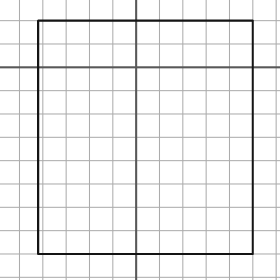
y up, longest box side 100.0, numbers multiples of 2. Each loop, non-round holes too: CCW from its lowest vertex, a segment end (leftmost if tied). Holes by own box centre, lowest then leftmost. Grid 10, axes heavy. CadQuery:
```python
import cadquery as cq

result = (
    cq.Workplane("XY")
    .moveTo(-42.0, -80.0)
    .lineTo(50.0, -80.0)
    .lineTo(50.0, 20.0)
    .lineTo(-42.0, 20.0)
    .close()
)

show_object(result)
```